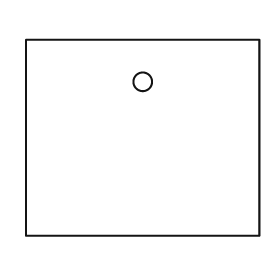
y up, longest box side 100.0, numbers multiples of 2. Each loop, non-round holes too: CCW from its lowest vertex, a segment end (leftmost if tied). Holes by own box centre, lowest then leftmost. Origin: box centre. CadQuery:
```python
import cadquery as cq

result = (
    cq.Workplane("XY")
    .moveTo(-50.0, -42.0)
    .lineTo(50.0, -42.0)
    .lineTo(50.0, 42.0)
    .lineTo(-50.0, 42.0)
    .close()
    .moveTo(0.0, 24.0)
    .circle(4.0)
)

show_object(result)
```